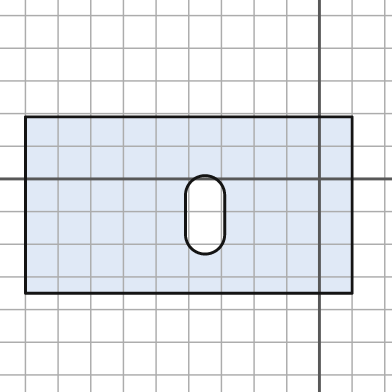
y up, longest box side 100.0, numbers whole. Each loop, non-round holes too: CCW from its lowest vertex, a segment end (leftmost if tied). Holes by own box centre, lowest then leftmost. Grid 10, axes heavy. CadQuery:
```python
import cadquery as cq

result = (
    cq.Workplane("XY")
    .moveTo(-90.0, -35.0)
    .lineTo(10.0, -35.0)
    .lineTo(10.0, 19.0)
    .lineTo(-90.0, 19.0)
    .close()
    .moveTo(-41.0, -17.0)
    .threePointArc((-35.0, -23.0), (-29.0, -17.0))
    .lineTo(-29.0, -5.0)
    .threePointArc((-35.0, 1.0), (-41.0, -5.0))
    .close()
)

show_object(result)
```